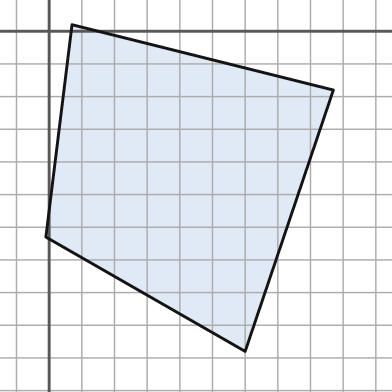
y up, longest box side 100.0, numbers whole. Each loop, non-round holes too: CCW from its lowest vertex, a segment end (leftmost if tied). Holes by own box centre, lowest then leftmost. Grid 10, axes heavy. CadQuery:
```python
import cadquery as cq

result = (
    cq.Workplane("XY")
    .moveTo(60.0, -98.0)
    .lineTo(87.0, -18.0)
    .lineTo(7.0, 2.0)
    .lineTo(-1.0, -63.0)
    .close()
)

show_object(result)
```